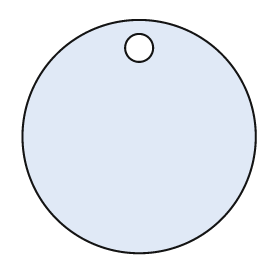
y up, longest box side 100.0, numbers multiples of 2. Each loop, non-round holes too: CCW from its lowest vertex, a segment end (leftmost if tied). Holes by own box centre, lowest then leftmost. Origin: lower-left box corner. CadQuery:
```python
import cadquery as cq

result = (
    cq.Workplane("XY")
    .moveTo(50.0, 50.0)
    .circle(50.0)
    .moveTo(50.0, 88.0)
    .circle(6.0)
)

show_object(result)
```